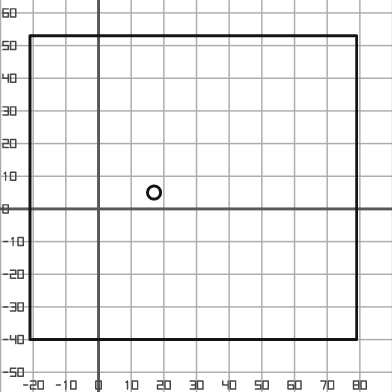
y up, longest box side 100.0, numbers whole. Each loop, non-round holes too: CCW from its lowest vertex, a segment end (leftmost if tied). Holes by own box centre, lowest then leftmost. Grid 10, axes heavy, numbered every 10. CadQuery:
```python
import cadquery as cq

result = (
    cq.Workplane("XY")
    .moveTo(-21.0, -40.0)
    .lineTo(79.0, -40.0)
    .lineTo(79.0, 53.0)
    .lineTo(-21.0, 53.0)
    .close()
    .moveTo(17.0, 5.0)
    .circle(2.0)
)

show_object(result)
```